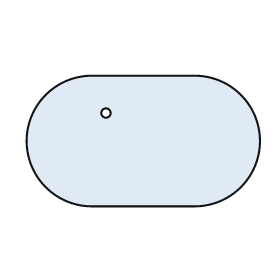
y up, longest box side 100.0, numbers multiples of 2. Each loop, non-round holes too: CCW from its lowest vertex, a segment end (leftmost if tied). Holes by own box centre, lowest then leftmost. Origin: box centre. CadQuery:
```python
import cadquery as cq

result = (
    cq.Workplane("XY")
    .moveTo(-22.0, -28.0)
    .lineTo(22.0, -28.0)
    .threePointArc((50.0, 0.0), (22.0, 28.0))
    .lineTo(-22.0, 28.0)
    .threePointArc((-50.0, 0.0), (-22.0, -28.0))
    .close()
    .moveTo(-16.0, 12.0)
    .circle(2.0)
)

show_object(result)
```